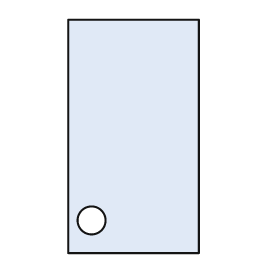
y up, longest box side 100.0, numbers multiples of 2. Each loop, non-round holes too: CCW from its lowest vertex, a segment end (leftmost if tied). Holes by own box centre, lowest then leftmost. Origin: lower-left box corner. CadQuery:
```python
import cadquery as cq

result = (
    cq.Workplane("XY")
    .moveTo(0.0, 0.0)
    .lineTo(56.0, 0.0)
    .lineTo(56.0, 100.0)
    .lineTo(0.0, 100.0)
    .close()
    .moveTo(10.0, 14.0)
    .circle(6.0)
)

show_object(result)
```